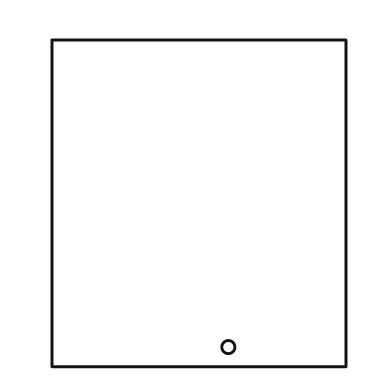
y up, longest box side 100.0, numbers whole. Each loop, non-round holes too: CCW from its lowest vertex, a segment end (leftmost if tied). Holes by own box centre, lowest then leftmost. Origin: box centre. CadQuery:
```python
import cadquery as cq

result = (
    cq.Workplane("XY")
    .moveTo(-45.0, -50.0)
    .lineTo(45.0, -50.0)
    .lineTo(45.0, 50.0)
    .lineTo(-45.0, 50.0)
    .close()
    .moveTo(9.0, -44.0)
    .circle(2.0)
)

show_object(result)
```